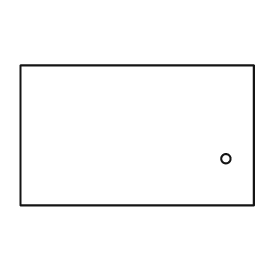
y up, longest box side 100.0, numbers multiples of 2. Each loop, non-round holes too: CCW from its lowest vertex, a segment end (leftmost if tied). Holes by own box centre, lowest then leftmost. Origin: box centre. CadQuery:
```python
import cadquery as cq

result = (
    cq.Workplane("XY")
    .moveTo(-50.0, -30.0)
    .lineTo(50.0, -30.0)
    .lineTo(50.0, 30.0)
    .lineTo(-50.0, 30.0)
    .close()
    .moveTo(38.0, -10.0)
    .circle(2.0)
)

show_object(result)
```